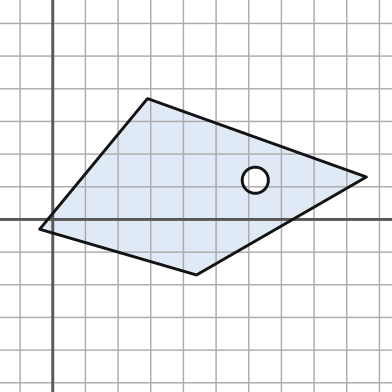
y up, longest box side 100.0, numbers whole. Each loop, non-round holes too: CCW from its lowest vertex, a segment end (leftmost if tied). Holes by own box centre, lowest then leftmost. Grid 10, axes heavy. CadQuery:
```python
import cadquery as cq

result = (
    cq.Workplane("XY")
    .moveTo(44.0, -17.0)
    .lineTo(96.0, 13.0)
    .lineTo(29.0, 37.0)
    .lineTo(-4.0, -3.0)
    .close()
    .moveTo(62.0, 12.0)
    .circle(4.0)
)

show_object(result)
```